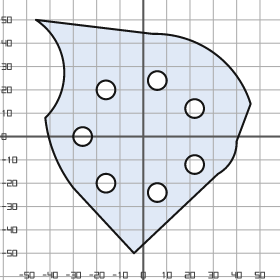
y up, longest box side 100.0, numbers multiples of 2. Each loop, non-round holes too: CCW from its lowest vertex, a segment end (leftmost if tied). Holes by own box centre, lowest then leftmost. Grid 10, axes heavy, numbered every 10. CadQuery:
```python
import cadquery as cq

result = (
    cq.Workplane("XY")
    .moveTo(-4.0, -50.0)
    .lineTo(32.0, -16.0)
    .threePointArc((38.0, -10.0), (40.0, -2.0))
    .lineTo(46.0, 14.0)
    .threePointArc((30.0, 36.0), (4.0, 44.0))
    .lineTo(-46.0, 50.0)
    .threePointArc((-34.0, 30.0), (-42.0, 8.0))
    .threePointArc((-38.0, -8.0), (-30.0, -22.0))
    .close()
    .moveTo(6.0, -24.0)
    .circle(4.0)
    .moveTo(-16.0, -20.0)
    .circle(4.0)
    .moveTo(22.0, -12.0)
    .circle(4.0)
    .moveTo(-26.0, 0.0)
    .circle(4.0)
    .moveTo(22.0, 12.0)
    .circle(4.0)
    .moveTo(-16.0, 20.0)
    .circle(4.0)
    .moveTo(6.0, 24.0)
    .circle(4.0)
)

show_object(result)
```